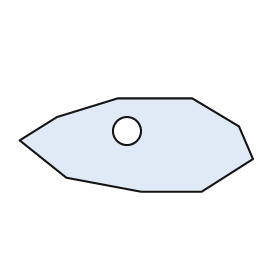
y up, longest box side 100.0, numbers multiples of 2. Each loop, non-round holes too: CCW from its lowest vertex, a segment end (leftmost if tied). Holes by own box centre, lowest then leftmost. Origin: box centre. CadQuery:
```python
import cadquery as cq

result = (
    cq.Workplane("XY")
    .moveTo(2.0, -20.0)
    .lineTo(28.0, -20.0)
    .lineTo(50.0, -6.0)
    .lineTo(44.0, 8.0)
    .lineTo(24.0, 20.0)
    .lineTo(-8.0, 20.0)
    .lineTo(-34.0, 12.0)
    .lineTo(-50.0, 2.0)
    .lineTo(-30.0, -14.0)
    .close()
    .moveTo(-4.0, 6.0)
    .circle(6.0)
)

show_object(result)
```